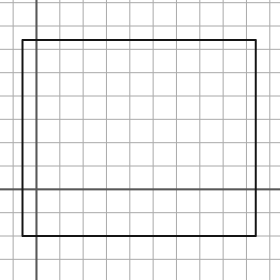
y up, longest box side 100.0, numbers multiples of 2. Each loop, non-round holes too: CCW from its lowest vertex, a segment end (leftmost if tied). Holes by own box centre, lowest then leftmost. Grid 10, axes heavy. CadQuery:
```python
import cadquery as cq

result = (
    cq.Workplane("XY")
    .moveTo(-6.0, -20.0)
    .lineTo(94.0, -20.0)
    .lineTo(94.0, 64.0)
    .lineTo(-6.0, 64.0)
    .close()
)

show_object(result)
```